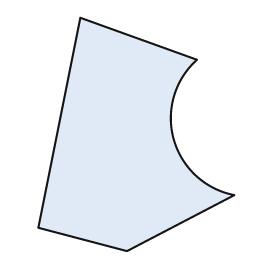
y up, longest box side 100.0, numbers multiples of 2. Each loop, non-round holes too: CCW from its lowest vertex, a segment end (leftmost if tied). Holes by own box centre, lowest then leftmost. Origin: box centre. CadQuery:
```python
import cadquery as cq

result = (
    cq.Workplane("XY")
    .moveTo(-4.0, -50.0)
    .lineTo(42.0, -26.0)
    .threePointArc((16.0, -2.0), (26.0, 32.0))
    .lineTo(-24.0, 50.0)
    .lineTo(-42.0, -40.0)
    .close()
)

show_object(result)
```